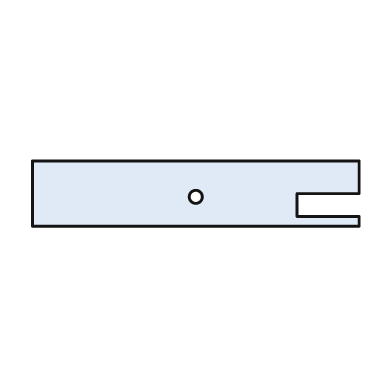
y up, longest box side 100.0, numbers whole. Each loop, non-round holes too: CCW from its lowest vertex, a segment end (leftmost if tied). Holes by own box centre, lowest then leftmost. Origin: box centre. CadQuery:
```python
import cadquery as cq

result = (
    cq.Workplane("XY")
    .moveTo(-50.0, -10.0)
    .lineTo(50.0, -10.0)
    .lineTo(50.0, -7.0)
    .lineTo(31.0, -7.0)
    .lineTo(31.0, 0.0)
    .lineTo(50.0, 0.0)
    .lineTo(50.0, 10.0)
    .lineTo(-50.0, 10.0)
    .close()
    .moveTo(0.0, -1.0)
    .circle(2.0)
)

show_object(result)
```